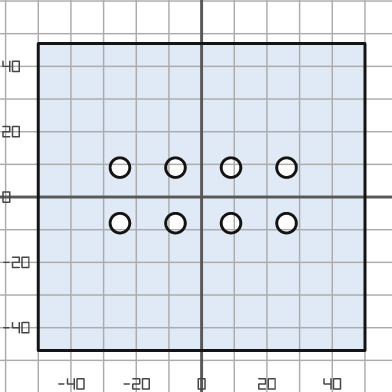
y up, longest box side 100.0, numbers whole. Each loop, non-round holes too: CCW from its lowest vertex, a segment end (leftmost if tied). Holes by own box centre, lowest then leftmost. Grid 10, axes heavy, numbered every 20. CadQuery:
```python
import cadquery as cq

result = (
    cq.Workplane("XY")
    .moveTo(-50.0, -47.0)
    .lineTo(50.0, -47.0)
    .lineTo(50.0, 47.0)
    .lineTo(-50.0, 47.0)
    .close()
    .moveTo(-25.0, -8.0)
    .circle(3.0)
    .moveTo(-8.0, -8.0)
    .circle(3.0)
    .moveTo(9.0, -8.0)
    .circle(3.0)
    .moveTo(26.0, -8.0)
    .circle(3.0)
    .moveTo(-25.0, 9.0)
    .circle(3.0)
    .moveTo(-8.0, 9.0)
    .circle(3.0)
    .moveTo(9.0, 9.0)
    .circle(3.0)
    .moveTo(26.0, 9.0)
    .circle(3.0)
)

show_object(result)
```